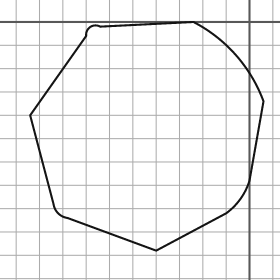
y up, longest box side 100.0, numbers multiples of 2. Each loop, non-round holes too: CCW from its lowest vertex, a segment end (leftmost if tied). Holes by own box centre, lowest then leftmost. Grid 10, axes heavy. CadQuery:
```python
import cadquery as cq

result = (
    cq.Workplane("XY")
    .moveTo(-40.0, -98.0)
    .lineTo(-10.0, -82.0)
    .threePointArc((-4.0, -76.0), (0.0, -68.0))
    .lineTo(6.0, -34.0)
    .threePointArc((-6.0, -14.0), (-24.0, 0.0))
    .lineTo(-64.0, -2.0)
    .threePointArc((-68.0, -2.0), (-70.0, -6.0))
    .lineTo(-94.0, -40.0)
    .lineTo(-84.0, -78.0)
    .threePointArc((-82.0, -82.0), (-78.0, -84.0))
    .close()
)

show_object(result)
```